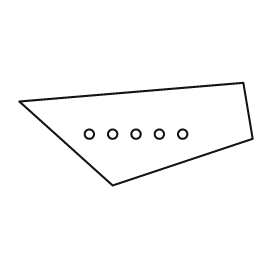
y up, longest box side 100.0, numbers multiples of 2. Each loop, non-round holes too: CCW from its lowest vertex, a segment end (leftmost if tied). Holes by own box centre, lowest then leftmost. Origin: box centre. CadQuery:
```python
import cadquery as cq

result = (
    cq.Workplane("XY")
    .moveTo(-10.0, -22.0)
    .lineTo(50.0, -2.0)
    .lineTo(46.0, 22.0)
    .lineTo(-50.0, 14.0)
    .close()
    .moveTo(-20.0, 0.0)
    .circle(2.0)
    .moveTo(-10.0, 0.0)
    .circle(2.0)
    .moveTo(0.0, 0.0)
    .circle(2.0)
    .moveTo(10.0, 0.0)
    .circle(2.0)
    .moveTo(20.0, 0.0)
    .circle(2.0)
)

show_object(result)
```